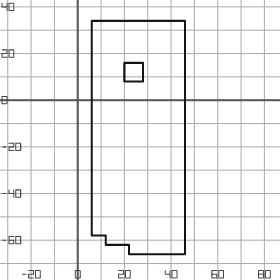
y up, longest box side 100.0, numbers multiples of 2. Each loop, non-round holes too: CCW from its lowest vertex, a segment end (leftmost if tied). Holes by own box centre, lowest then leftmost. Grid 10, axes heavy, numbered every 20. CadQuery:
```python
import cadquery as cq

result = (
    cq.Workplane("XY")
    .moveTo(22.0, -66.0)
    .lineTo(46.0, -66.0)
    .lineTo(46.0, 34.0)
    .lineTo(6.0, 34.0)
    .lineTo(6.0, -58.0)
    .lineTo(12.0, -58.0)
    .lineTo(12.0, -62.0)
    .lineTo(22.0, -62.0)
    .close()
    .moveTo(20.0, 8.0)
    .lineTo(28.0, 8.0)
    .lineTo(28.0, 16.0)
    .lineTo(20.0, 16.0)
    .close()
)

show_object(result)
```